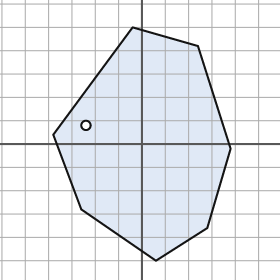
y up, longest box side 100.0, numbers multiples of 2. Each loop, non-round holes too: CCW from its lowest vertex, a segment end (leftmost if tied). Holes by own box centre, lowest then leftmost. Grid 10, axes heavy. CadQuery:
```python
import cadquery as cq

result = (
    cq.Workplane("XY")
    .moveTo(6.0, -50.0)
    .lineTo(28.0, -36.0)
    .lineTo(38.0, -2.0)
    .lineTo(24.0, 42.0)
    .lineTo(-4.0, 50.0)
    .lineTo(-38.0, 4.0)
    .lineTo(-26.0, -28.0)
    .close()
    .moveTo(-24.0, 8.0)
    .circle(2.0)
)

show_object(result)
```